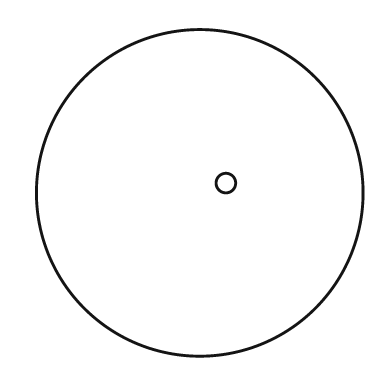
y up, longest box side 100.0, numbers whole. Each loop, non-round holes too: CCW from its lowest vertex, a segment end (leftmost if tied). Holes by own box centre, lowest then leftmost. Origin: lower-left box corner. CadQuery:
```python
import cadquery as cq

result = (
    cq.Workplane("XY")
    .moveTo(50.0, 50.0)
    .circle(50.0)
    .moveTo(58.0, 53.0)
    .circle(3.0)
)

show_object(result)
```